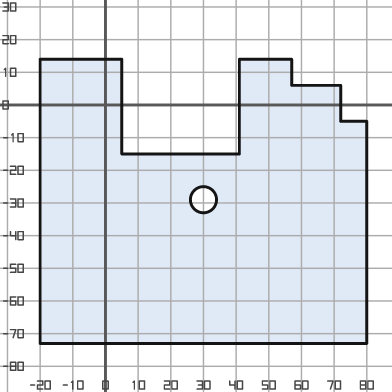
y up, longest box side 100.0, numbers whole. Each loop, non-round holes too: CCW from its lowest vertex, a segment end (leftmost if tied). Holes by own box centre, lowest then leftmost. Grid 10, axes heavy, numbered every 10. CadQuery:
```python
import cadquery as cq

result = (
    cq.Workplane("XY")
    .moveTo(-20.0, -73.0)
    .lineTo(80.0, -73.0)
    .lineTo(80.0, -5.0)
    .lineTo(72.0, -5.0)
    .lineTo(72.0, 6.0)
    .lineTo(57.0, 6.0)
    .lineTo(57.0, 14.0)
    .lineTo(41.0, 14.0)
    .lineTo(41.0, -15.0)
    .lineTo(5.0, -15.0)
    .lineTo(5.0, 14.0)
    .lineTo(-20.0, 14.0)
    .close()
    .moveTo(30.0, -29.0)
    .circle(4.0)
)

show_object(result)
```